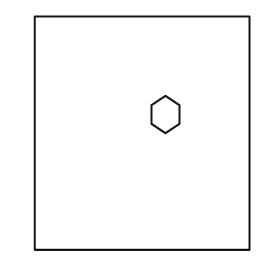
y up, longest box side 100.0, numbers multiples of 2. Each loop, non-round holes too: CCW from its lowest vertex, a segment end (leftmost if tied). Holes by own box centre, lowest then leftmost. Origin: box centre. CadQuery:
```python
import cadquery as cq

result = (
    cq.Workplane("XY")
    .moveTo(-46.0, -50.0)
    .lineTo(46.0, -50.0)
    .lineTo(46.0, 50.0)
    .lineTo(-46.0, 50.0)
    .close()
    .moveTo(10.0, 0.0)
    .lineTo(16.0, 4.0)
    .lineTo(16.0, 12.0)
    .lineTo(10.0, 16.0)
    .lineTo(4.0, 12.0)
    .lineTo(4.0, 4.0)
    .close()
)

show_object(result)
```